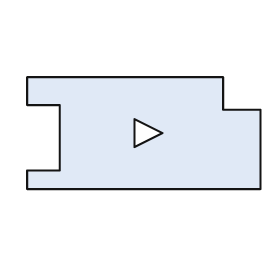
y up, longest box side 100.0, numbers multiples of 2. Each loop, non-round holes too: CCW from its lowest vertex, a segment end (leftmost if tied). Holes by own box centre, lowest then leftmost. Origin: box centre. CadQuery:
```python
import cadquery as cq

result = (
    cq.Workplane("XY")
    .moveTo(-50.0, -24.0)
    .lineTo(50.0, -24.0)
    .lineTo(50.0, 10.0)
    .lineTo(34.0, 10.0)
    .lineTo(34.0, 24.0)
    .lineTo(-50.0, 24.0)
    .lineTo(-50.0, 12.0)
    .lineTo(-36.0, 12.0)
    .lineTo(-36.0, -16.0)
    .lineTo(-50.0, -16.0)
    .close()
    .moveTo(-4.0, -6.0)
    .lineTo(8.0, 0.0)
    .lineTo(-4.0, 6.0)
    .close()
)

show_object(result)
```